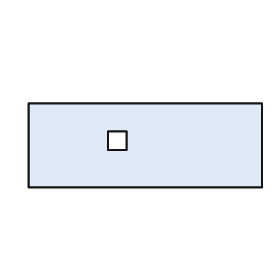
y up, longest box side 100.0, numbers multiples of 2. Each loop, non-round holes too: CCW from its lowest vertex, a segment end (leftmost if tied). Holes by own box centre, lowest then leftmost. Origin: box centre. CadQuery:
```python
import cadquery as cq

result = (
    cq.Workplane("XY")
    .moveTo(-50.0, -18.0)
    .lineTo(50.0, -18.0)
    .lineTo(50.0, 18.0)
    .lineTo(-50.0, 18.0)
    .close()
    .moveTo(-16.0, -2.0)
    .lineTo(-8.0, -2.0)
    .lineTo(-8.0, 6.0)
    .lineTo(-16.0, 6.0)
    .close()
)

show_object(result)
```